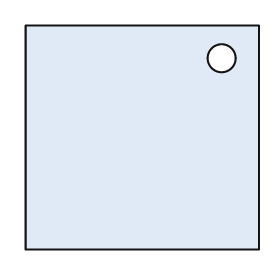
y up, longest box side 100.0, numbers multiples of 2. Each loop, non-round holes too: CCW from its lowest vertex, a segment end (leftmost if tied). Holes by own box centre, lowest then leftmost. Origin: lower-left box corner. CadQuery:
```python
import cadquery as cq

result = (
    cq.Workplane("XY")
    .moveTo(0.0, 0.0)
    .lineTo(100.0, 0.0)
    .lineTo(100.0, 96.0)
    .lineTo(0.0, 96.0)
    .close()
    .moveTo(84.0, 82.0)
    .circle(6.0)
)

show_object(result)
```